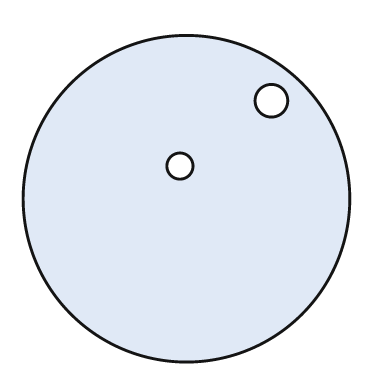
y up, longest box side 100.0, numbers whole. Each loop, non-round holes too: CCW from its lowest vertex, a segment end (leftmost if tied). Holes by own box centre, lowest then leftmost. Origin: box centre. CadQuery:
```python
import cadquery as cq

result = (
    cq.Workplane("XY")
    .moveTo(0.0, 0.0)
    .circle(50.0)
    .moveTo(-2.0, 10.0)
    .circle(4.0)
    .moveTo(26.0, 30.0)
    .circle(5.0)
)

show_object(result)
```